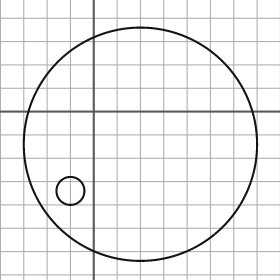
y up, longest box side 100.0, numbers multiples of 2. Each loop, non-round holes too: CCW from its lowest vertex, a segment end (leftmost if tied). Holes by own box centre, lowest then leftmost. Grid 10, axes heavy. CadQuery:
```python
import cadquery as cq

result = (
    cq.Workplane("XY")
    .moveTo(20.0, -14.0)
    .circle(50.0)
    .moveTo(-10.0, -34.0)
    .circle(6.0)
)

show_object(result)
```